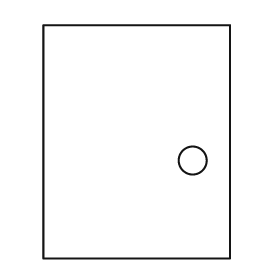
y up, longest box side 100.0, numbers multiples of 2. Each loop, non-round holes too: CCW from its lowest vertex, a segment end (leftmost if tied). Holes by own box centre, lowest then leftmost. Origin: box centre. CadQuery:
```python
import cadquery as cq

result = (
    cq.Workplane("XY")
    .moveTo(-40.0, -50.0)
    .lineTo(40.0, -50.0)
    .lineTo(40.0, 50.0)
    .lineTo(-40.0, 50.0)
    .close()
    .moveTo(24.0, -8.0)
    .circle(6.0)
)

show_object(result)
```